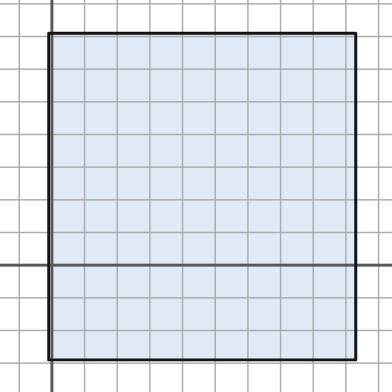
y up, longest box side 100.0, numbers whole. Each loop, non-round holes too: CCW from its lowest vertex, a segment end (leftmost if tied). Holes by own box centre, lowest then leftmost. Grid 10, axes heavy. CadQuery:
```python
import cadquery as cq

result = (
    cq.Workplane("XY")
    .moveTo(-1.0, -29.0)
    .lineTo(93.0, -29.0)
    .lineTo(93.0, 71.0)
    .lineTo(-1.0, 71.0)
    .close()
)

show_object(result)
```